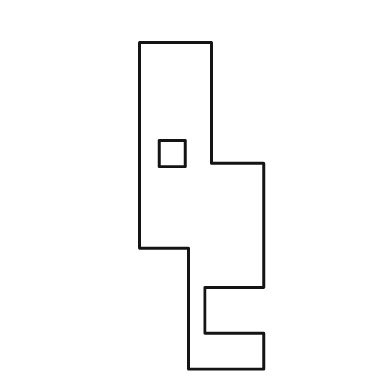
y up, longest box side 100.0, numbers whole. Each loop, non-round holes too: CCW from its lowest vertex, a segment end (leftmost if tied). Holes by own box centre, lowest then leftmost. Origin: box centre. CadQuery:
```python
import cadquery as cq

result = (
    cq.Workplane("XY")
    .moveTo(-4.0, -50.0)
    .lineTo(19.0, -50.0)
    .lineTo(19.0, -39.0)
    .lineTo(1.0, -39.0)
    .lineTo(1.0, -25.0)
    .lineTo(19.0, -25.0)
    .lineTo(19.0, 13.0)
    .lineTo(3.0, 13.0)
    .lineTo(3.0, 50.0)
    .lineTo(-19.0, 50.0)
    .lineTo(-19.0, -13.0)
    .lineTo(-4.0, -13.0)
    .close()
    .moveTo(-13.0, 12.0)
    .lineTo(-5.0, 12.0)
    .lineTo(-5.0, 20.0)
    .lineTo(-13.0, 20.0)
    .close()
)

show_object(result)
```